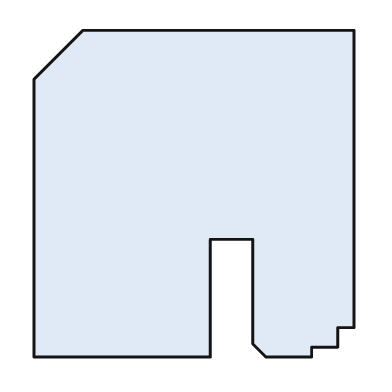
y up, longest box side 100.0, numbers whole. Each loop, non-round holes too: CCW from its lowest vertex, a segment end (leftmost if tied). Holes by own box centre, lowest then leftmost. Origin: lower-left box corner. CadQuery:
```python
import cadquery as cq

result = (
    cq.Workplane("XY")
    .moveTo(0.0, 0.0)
    .lineTo(54.0, 0.0)
    .lineTo(54.0, 36.0)
    .lineTo(67.0, 36.0)
    .lineTo(67.0, 4.0)
    .lineTo(71.0, 0.0)
    .lineTo(85.0, 0.0)
    .lineTo(85.0, 3.0)
    .lineTo(93.0, 3.0)
    .lineTo(93.0, 9.0)
    .lineTo(98.0, 9.0)
    .lineTo(98.0, 100.0)
    .lineTo(15.0, 100.0)
    .lineTo(0.0, 85.0)
    .close()
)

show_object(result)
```